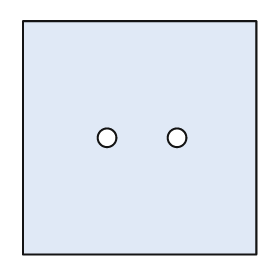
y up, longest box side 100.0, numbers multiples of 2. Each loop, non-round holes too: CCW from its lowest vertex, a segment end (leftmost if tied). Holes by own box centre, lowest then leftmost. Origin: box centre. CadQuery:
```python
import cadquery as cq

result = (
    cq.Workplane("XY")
    .moveTo(-50.0, -50.0)
    .lineTo(50.0, -50.0)
    .lineTo(50.0, 50.0)
    .lineTo(-50.0, 50.0)
    .close()
    .moveTo(-14.0, 0.0)
    .circle(4.0)
    .moveTo(16.0, 0.0)
    .circle(4.0)
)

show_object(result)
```